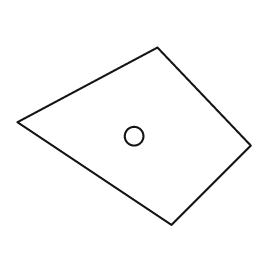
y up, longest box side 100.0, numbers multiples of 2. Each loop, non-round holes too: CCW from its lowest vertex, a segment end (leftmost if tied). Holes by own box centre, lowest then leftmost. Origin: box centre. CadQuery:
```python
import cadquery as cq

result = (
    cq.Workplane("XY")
    .moveTo(16.0, -38.0)
    .lineTo(50.0, -4.0)
    .lineTo(10.0, 38.0)
    .lineTo(-50.0, 6.0)
    .close()
    .moveTo(0.0, 0.0)
    .circle(4.0)
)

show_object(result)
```